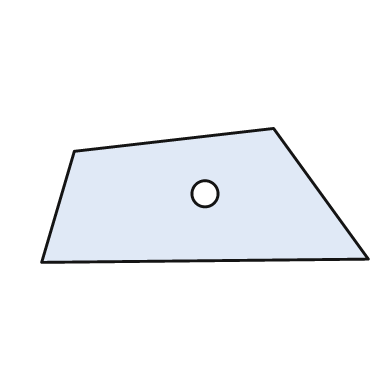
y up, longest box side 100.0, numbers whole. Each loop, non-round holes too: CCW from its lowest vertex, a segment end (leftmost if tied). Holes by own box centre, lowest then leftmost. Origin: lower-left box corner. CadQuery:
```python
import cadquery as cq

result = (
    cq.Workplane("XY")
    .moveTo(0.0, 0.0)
    .lineTo(100.0, 1.0)
    .lineTo(71.0, 41.0)
    .lineTo(10.0, 34.0)
    .close()
    .moveTo(50.0, 21.0)
    .circle(4.0)
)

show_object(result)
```